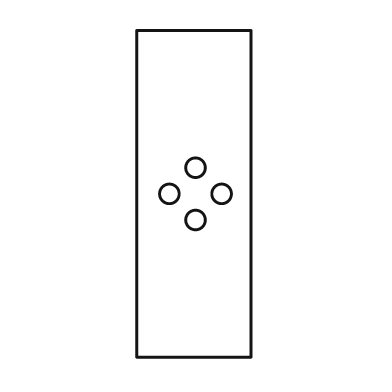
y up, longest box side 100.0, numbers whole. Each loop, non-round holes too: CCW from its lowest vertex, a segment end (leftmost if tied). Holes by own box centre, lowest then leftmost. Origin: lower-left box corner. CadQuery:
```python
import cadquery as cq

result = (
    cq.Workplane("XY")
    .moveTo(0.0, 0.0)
    .lineTo(35.0, 0.0)
    .lineTo(35.0, 100.0)
    .lineTo(0.0, 100.0)
    .close()
    .moveTo(18.0, 42.0)
    .circle(3.0)
    .moveTo(10.0, 50.0)
    .circle(3.0)
    .moveTo(26.0, 50.0)
    .circle(3.0)
    .moveTo(18.0, 58.0)
    .circle(3.0)
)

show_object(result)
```